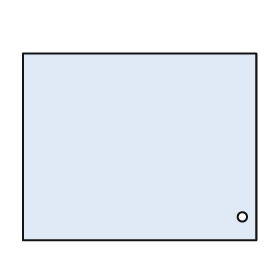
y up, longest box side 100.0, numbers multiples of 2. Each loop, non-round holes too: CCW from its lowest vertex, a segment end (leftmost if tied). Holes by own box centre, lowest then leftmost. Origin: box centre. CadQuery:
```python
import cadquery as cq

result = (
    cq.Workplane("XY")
    .moveTo(-50.0, -40.0)
    .lineTo(50.0, -40.0)
    .lineTo(50.0, 40.0)
    .lineTo(-50.0, 40.0)
    .close()
    .moveTo(44.0, -30.0)
    .circle(2.0)
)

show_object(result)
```